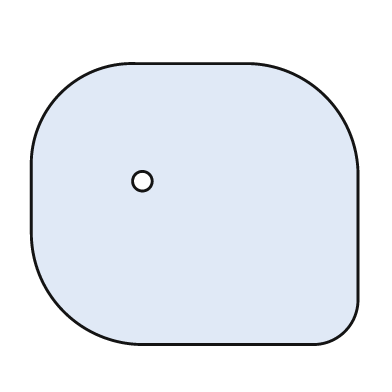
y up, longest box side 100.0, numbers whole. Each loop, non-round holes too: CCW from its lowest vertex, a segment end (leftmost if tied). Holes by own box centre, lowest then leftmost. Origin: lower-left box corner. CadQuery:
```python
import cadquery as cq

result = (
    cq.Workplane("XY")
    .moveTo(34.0, 0.0)
    .lineTo(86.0, 0.0)
    .threePointArc((96.0, 4.0), (100.0, 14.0))
    .lineTo(100.0, 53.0)
    .threePointArc((90.0, 76.0), (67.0, 86.0))
    .lineTo(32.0, 86.0)
    .threePointArc((9.0, 77.0), (0.0, 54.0))
    .lineTo(0.0, 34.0)
    .threePointArc((10.0, 10.0), (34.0, 0.0))
    .close()
    .moveTo(34.0, 50.0)
    .circle(3.0)
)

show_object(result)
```